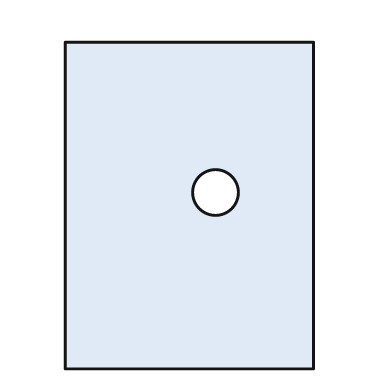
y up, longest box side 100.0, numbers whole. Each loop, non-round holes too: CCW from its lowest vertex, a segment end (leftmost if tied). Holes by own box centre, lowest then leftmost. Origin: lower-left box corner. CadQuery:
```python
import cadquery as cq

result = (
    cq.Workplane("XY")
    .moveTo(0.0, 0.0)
    .lineTo(76.0, 0.0)
    .lineTo(76.0, 100.0)
    .lineTo(0.0, 100.0)
    .close()
    .moveTo(46.0, 54.0)
    .circle(7.0)
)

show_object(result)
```